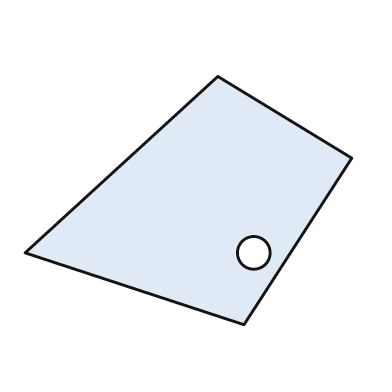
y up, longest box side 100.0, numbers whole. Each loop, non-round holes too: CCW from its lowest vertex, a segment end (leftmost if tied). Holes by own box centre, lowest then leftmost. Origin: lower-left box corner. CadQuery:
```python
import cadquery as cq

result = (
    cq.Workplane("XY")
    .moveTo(67.0, 0.0)
    .lineTo(100.0, 51.0)
    .lineTo(59.0, 76.0)
    .lineTo(0.0, 22.0)
    .close()
    .moveTo(70.0, 22.0)
    .circle(5.0)
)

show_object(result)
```